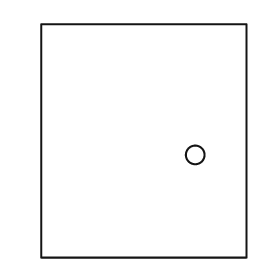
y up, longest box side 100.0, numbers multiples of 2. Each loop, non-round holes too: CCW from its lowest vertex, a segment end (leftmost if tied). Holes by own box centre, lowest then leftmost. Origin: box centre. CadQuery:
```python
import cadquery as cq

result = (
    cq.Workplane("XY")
    .moveTo(-44.0, -50.0)
    .lineTo(44.0, -50.0)
    .lineTo(44.0, 50.0)
    .lineTo(-44.0, 50.0)
    .close()
    .moveTo(22.0, -6.0)
    .circle(4.0)
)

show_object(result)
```